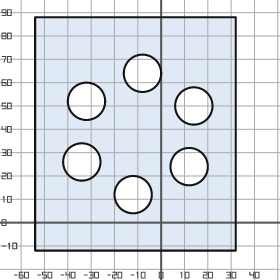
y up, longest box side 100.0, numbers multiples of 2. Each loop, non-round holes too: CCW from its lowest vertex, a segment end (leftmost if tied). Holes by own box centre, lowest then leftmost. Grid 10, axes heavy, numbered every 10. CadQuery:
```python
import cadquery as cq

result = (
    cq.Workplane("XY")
    .moveTo(-54.0, -12.0)
    .lineTo(32.0, -12.0)
    .lineTo(32.0, 88.0)
    .lineTo(-54.0, 88.0)
    .close()
    .moveTo(-12.0, 12.0)
    .circle(8.0)
    .moveTo(12.0, 24.0)
    .circle(8.0)
    .moveTo(-34.0, 26.0)
    .circle(8.0)
    .moveTo(14.0, 50.0)
    .circle(8.0)
    .moveTo(-32.0, 52.0)
    .circle(8.0)
    .moveTo(-8.0, 64.0)
    .circle(8.0)
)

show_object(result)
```